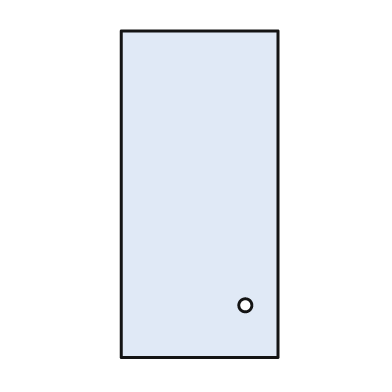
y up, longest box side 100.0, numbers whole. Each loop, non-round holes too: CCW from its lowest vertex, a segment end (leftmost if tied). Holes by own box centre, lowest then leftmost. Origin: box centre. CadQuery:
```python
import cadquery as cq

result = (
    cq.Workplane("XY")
    .moveTo(-24.0, -50.0)
    .lineTo(24.0, -50.0)
    .lineTo(24.0, 50.0)
    .lineTo(-24.0, 50.0)
    .close()
    .moveTo(14.0, -34.0)
    .circle(2.0)
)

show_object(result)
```